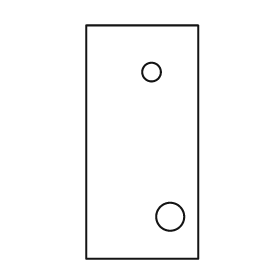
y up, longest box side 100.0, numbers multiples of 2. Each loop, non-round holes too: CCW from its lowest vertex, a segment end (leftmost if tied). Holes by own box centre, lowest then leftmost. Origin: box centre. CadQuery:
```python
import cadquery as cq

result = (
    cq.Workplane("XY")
    .moveTo(-24.0, -50.0)
    .lineTo(24.0, -50.0)
    .lineTo(24.0, 50.0)
    .lineTo(-24.0, 50.0)
    .close()
    .moveTo(12.0, -32.0)
    .circle(6.0)
    .moveTo(4.0, 30.0)
    .circle(4.0)
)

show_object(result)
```